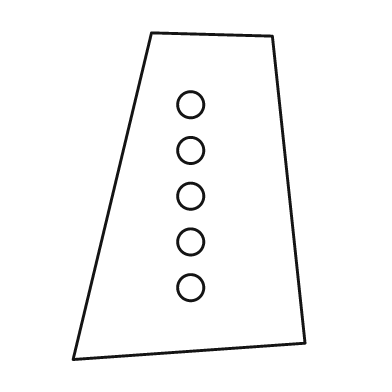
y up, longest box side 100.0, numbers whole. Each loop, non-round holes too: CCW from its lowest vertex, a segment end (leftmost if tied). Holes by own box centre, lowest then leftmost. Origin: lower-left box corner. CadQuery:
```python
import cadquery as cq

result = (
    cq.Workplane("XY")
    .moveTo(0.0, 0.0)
    .lineTo(71.0, 5.0)
    .lineTo(61.0, 99.0)
    .lineTo(24.0, 100.0)
    .close()
    .moveTo(36.0, 22.0)
    .circle(4.0)
    .moveTo(36.0, 36.0)
    .circle(4.0)
    .moveTo(36.0, 50.0)
    .circle(4.0)
    .moveTo(36.0, 64.0)
    .circle(4.0)
    .moveTo(36.0, 78.0)
    .circle(4.0)
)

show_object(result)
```